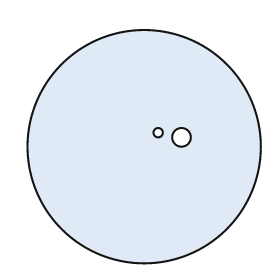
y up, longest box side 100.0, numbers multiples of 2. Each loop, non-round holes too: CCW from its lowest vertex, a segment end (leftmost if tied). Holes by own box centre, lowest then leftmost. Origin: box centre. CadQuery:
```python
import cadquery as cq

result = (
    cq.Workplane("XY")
    .moveTo(0.0, 0.0)
    .circle(50.0)
    .moveTo(16.0, 4.0)
    .circle(4.0)
    .moveTo(6.0, 6.0)
    .circle(2.0)
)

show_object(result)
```